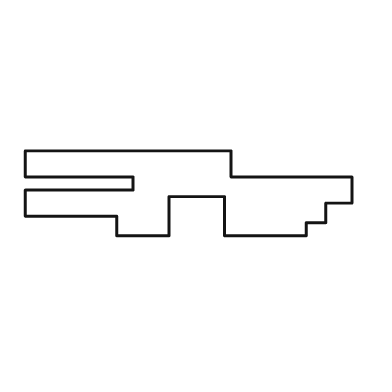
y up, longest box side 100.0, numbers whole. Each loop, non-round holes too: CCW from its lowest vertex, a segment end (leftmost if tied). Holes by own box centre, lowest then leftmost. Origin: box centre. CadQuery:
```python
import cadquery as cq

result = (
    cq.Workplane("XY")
    .moveTo(-22.0, -13.0)
    .lineTo(-6.0, -13.0)
    .lineTo(-6.0, -1.0)
    .lineTo(11.0, -1.0)
    .lineTo(11.0, -13.0)
    .lineTo(36.0, -13.0)
    .lineTo(36.0, -9.0)
    .lineTo(42.0, -9.0)
    .lineTo(42.0, -3.0)
    .lineTo(50.0, -3.0)
    .lineTo(50.0, 5.0)
    .lineTo(13.0, 5.0)
    .lineTo(13.0, 13.0)
    .lineTo(-50.0, 13.0)
    .lineTo(-50.0, 5.0)
    .lineTo(-17.0, 5.0)
    .lineTo(-17.0, 1.0)
    .lineTo(-50.0, 1.0)
    .lineTo(-50.0, -7.0)
    .lineTo(-22.0, -7.0)
    .close()
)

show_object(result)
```